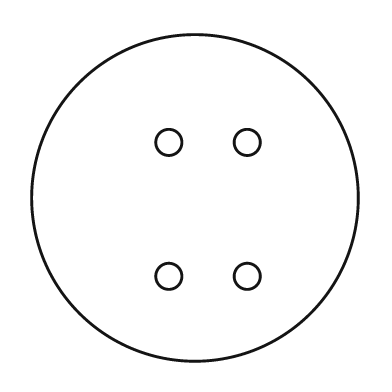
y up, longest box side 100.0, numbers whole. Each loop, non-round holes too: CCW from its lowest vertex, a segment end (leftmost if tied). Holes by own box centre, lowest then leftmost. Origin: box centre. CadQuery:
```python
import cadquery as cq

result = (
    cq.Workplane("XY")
    .moveTo(0.0, 0.0)
    .circle(50.0)
    .moveTo(-8.0, -24.0)
    .circle(4.0)
    .moveTo(16.0, -24.0)
    .circle(4.0)
    .moveTo(-8.0, 17.0)
    .circle(4.0)
    .moveTo(16.0, 17.0)
    .circle(4.0)
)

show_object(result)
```